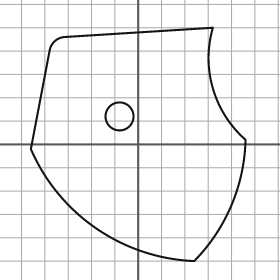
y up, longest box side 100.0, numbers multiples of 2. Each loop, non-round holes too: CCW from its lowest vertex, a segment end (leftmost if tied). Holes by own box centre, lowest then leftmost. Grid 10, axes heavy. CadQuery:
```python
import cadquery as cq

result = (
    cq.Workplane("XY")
    .moveTo(24.0, -50.0)
    .threePointArc((40.0, -26.0), (46.0, 2.0))
    .threePointArc((32.0, 24.0), (32.0, 50.0))
    .lineTo(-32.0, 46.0)
    .threePointArc((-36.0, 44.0), (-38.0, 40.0))
    .lineTo(-46.0, -2.0)
    .threePointArc((-18.0, -36.0), (24.0, -50.0))
    .close()
    .moveTo(-8.0, 12.0)
    .circle(6.0)
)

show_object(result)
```